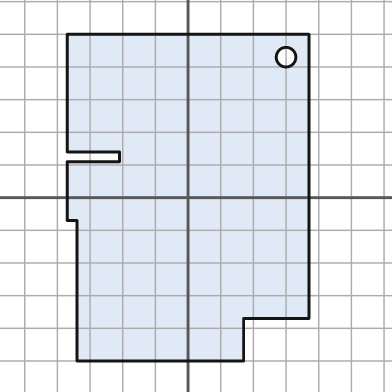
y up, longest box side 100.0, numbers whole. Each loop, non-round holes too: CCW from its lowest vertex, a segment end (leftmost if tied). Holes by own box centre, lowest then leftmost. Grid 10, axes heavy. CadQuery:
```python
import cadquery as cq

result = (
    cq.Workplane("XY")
    .moveTo(-34.0, -50.0)
    .lineTo(17.0, -50.0)
    .lineTo(17.0, -37.0)
    .lineTo(37.0, -37.0)
    .lineTo(37.0, 50.0)
    .lineTo(-37.0, 50.0)
    .lineTo(-37.0, 14.0)
    .lineTo(-21.0, 14.0)
    .lineTo(-21.0, 11.0)
    .lineTo(-37.0, 11.0)
    .lineTo(-37.0, -7.0)
    .lineTo(-34.0, -7.0)
    .close()
    .moveTo(30.0, 43.0)
    .circle(3.0)
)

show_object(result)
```